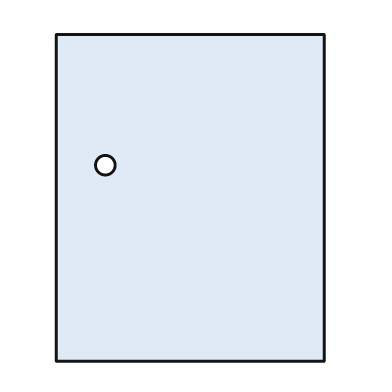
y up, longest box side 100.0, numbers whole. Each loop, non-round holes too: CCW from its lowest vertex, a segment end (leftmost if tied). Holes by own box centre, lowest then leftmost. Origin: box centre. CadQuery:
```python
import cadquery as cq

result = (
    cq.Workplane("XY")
    .moveTo(-41.0, -50.0)
    .lineTo(41.0, -50.0)
    .lineTo(41.0, 50.0)
    .lineTo(-41.0, 50.0)
    .close()
    .moveTo(-26.0, 10.0)
    .circle(3.0)
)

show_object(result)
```